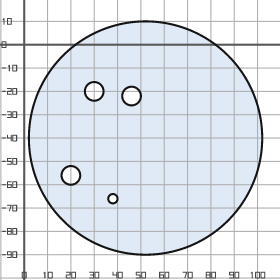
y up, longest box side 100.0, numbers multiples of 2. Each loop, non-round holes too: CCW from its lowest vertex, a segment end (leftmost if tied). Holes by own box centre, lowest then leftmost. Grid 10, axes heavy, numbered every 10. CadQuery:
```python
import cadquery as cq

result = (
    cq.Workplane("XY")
    .moveTo(52.0, -40.0)
    .circle(50.0)
    .moveTo(38.0, -66.0)
    .circle(2.0)
    .moveTo(20.0, -56.0)
    .circle(4.0)
    .moveTo(46.0, -22.0)
    .circle(4.0)
    .moveTo(30.0, -20.0)
    .circle(4.0)
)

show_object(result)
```